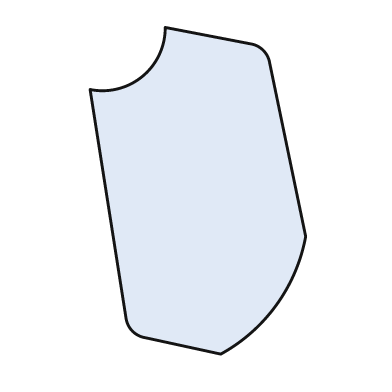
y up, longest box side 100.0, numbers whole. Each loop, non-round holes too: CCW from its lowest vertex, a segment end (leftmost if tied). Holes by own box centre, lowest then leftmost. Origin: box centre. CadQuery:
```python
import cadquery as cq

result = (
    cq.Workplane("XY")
    .moveTo(7.0, -50.0)
    .threePointArc((24.0, -35.0), (33.0, -14.0))
    .lineTo(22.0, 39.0)
    .threePointArc((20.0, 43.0), (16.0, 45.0))
    .lineTo(-10.0, 50.0)
    .threePointArc((-17.0, 35.0), (-33.0, 31.0))
    .lineTo(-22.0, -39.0)
    .threePointArc((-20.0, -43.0), (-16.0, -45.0))
    .close()
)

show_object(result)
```